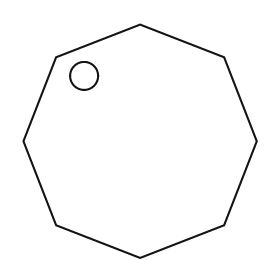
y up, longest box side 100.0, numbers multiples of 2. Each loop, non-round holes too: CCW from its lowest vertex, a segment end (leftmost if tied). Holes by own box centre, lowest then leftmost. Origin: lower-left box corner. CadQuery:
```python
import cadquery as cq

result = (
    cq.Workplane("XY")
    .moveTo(50.0, 0.0)
    .lineTo(86.0, 14.0)
    .lineTo(100.0, 50.0)
    .lineTo(86.0, 86.0)
    .lineTo(50.0, 100.0)
    .lineTo(14.0, 86.0)
    .lineTo(0.0, 50.0)
    .lineTo(14.0, 14.0)
    .close()
    .moveTo(26.0, 78.0)
    .circle(6.0)
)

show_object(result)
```